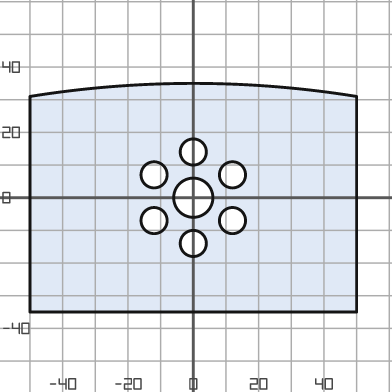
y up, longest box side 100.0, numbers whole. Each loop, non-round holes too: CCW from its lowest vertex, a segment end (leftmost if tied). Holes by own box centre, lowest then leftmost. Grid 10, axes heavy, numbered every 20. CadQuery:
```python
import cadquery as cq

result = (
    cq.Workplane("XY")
    .moveTo(-50.0, -35.0)
    .lineTo(50.0, -35.0)
    .lineTo(50.0, 31.0)
    .threePointArc((0.0, 35.0), (-50.0, 31.0))
    .close()
    .moveTo(0.0, -14.0)
    .circle(4.0)
    .moveTo(-12.0, -7.0)
    .circle(4.0)
    .moveTo(12.0, -7.0)
    .circle(4.0)
    .moveTo(0.0, 0.0)
    .circle(6.0)
    .moveTo(-12.0, 7.0)
    .circle(4.0)
    .moveTo(12.0, 7.0)
    .circle(4.0)
    .moveTo(0.0, 14.0)
    .circle(4.0)
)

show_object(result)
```